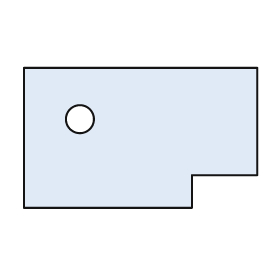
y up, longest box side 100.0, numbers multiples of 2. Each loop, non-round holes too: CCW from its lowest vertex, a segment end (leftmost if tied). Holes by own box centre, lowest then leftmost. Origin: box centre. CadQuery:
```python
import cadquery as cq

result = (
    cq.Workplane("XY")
    .moveTo(-50.0, -30.0)
    .lineTo(22.0, -30.0)
    .lineTo(22.0, -16.0)
    .lineTo(50.0, -16.0)
    .lineTo(50.0, 30.0)
    .lineTo(-50.0, 30.0)
    .close()
    .moveTo(-26.0, 8.0)
    .circle(6.0)
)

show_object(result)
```